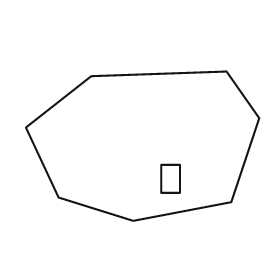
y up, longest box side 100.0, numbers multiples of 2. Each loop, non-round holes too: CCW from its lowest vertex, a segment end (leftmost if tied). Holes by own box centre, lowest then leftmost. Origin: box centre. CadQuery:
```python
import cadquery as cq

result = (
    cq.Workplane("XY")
    .moveTo(-4.0, -32.0)
    .lineTo(38.0, -24.0)
    .lineTo(50.0, 12.0)
    .lineTo(36.0, 32.0)
    .lineTo(-22.0, 30.0)
    .lineTo(-50.0, 8.0)
    .lineTo(-36.0, -22.0)
    .close()
    .moveTo(8.0, -20.0)
    .lineTo(16.0, -20.0)
    .lineTo(16.0, -8.0)
    .lineTo(8.0, -8.0)
    .close()
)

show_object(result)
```